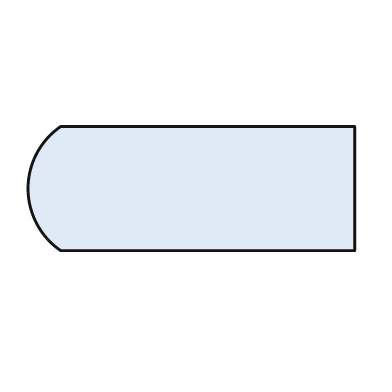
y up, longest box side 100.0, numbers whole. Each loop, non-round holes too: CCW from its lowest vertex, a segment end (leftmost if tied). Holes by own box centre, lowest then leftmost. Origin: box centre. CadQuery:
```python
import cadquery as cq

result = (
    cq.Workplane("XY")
    .moveTo(-40.0, -19.0)
    .lineTo(50.0, -19.0)
    .lineTo(50.0, 19.0)
    .lineTo(-40.0, 19.0)
    .threePointArc((-50.0, 0.0), (-40.0, -19.0))
    .close()
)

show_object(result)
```